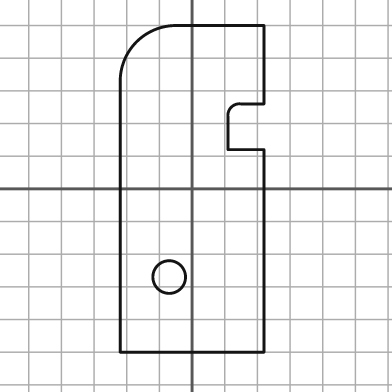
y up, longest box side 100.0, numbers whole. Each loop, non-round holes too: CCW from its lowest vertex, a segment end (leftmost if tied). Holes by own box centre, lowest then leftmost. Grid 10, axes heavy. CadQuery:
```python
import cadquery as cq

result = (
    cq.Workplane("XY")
    .moveTo(-22.0, -50.0)
    .lineTo(22.0, -50.0)
    .lineTo(22.0, 12.0)
    .lineTo(11.0, 12.0)
    .lineTo(11.0, 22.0)
    .threePointArc((12.0, 25.0), (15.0, 26.0))
    .lineTo(22.0, 26.0)
    .lineTo(22.0, 50.0)
    .lineTo(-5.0, 50.0)
    .threePointArc((-17.0, 45.0), (-22.0, 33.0))
    .close()
    .moveTo(-7.0, -27.0)
    .circle(5.0)
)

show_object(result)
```